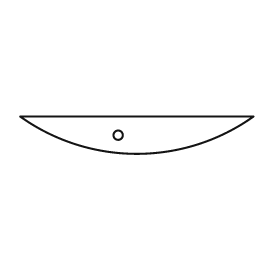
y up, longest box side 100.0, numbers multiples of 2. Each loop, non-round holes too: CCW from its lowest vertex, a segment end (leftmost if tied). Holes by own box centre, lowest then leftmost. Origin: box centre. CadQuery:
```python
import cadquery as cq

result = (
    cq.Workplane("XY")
    .moveTo(-50.0, 8.0)
    .threePointArc((0.0, -8.0), (50.0, 8.0))
    .close()
    .moveTo(-8.0, 0.0)
    .circle(2.0)
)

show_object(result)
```